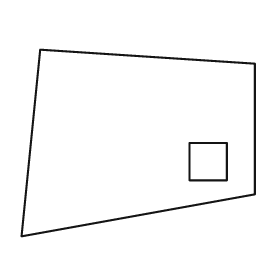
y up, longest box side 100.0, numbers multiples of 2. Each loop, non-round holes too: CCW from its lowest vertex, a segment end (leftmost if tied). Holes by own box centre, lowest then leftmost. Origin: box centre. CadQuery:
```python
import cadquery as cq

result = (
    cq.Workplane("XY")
    .moveTo(-50.0, -40.0)
    .lineTo(50.0, -22.0)
    .lineTo(50.0, 34.0)
    .lineTo(-42.0, 40.0)
    .close()
    .moveTo(22.0, -16.0)
    .lineTo(38.0, -16.0)
    .lineTo(38.0, 0.0)
    .lineTo(22.0, 0.0)
    .close()
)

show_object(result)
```